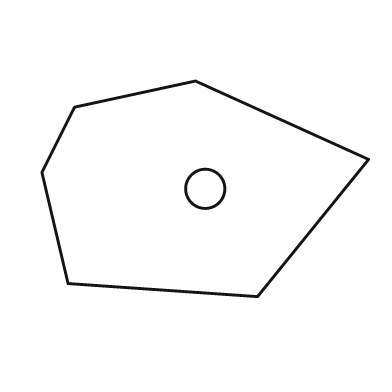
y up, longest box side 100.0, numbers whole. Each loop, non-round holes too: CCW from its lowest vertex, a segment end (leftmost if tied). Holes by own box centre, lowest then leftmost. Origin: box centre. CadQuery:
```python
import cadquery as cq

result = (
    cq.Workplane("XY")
    .moveTo(16.0, -33.0)
    .lineTo(50.0, 9.0)
    .lineTo(-3.0, 33.0)
    .lineTo(-40.0, 25.0)
    .lineTo(-50.0, 5.0)
    .lineTo(-42.0, -29.0)
    .close()
    .moveTo(0.0, 0.0)
    .circle(6.0)
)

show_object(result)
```